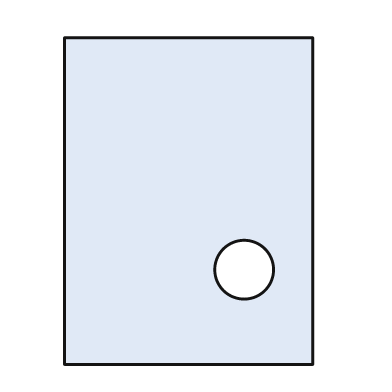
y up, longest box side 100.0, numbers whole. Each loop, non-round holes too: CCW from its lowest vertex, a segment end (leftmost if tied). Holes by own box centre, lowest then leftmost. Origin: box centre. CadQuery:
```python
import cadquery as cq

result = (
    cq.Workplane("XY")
    .moveTo(-38.0, -50.0)
    .lineTo(38.0, -50.0)
    .lineTo(38.0, 50.0)
    .lineTo(-38.0, 50.0)
    .close()
    .moveTo(17.0, -21.0)
    .circle(9.0)
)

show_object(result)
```